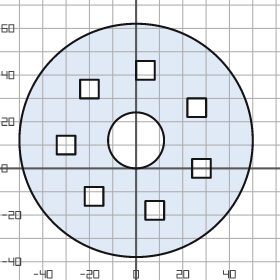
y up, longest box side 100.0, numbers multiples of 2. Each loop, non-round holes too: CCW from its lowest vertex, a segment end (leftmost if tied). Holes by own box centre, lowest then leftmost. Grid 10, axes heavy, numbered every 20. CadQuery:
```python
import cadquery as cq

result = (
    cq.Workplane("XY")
    .moveTo(0.0, 12.0)
    .circle(50.0)
    .moveTo(4.0, -22.0)
    .lineTo(12.0, -22.0)
    .lineTo(12.0, -14.0)
    .lineTo(4.0, -14.0)
    .close()
    .moveTo(-22.0, -16.0)
    .lineTo(-14.0, -16.0)
    .lineTo(-14.0, -8.0)
    .lineTo(-22.0, -8.0)
    .close()
    .moveTo(24.0, -4.0)
    .lineTo(32.0, -4.0)
    .lineTo(32.0, 4.0)
    .lineTo(24.0, 4.0)
    .close()
    .moveTo(-34.0, 6.0)
    .lineTo(-26.0, 6.0)
    .lineTo(-26.0, 14.0)
    .lineTo(-34.0, 14.0)
    .close()
    .moveTo(0.0, 12.0)
    .circle(12.0)
    .moveTo(22.0, 22.0)
    .lineTo(30.0, 22.0)
    .lineTo(30.0, 30.0)
    .lineTo(22.0, 30.0)
    .close()
    .moveTo(-24.0, 30.0)
    .lineTo(-16.0, 30.0)
    .lineTo(-16.0, 38.0)
    .lineTo(-24.0, 38.0)
    .close()
    .moveTo(0.0, 38.0)
    .lineTo(8.0, 38.0)
    .lineTo(8.0, 46.0)
    .lineTo(0.0, 46.0)
    .close()
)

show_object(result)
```